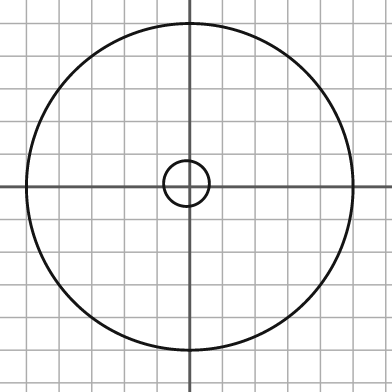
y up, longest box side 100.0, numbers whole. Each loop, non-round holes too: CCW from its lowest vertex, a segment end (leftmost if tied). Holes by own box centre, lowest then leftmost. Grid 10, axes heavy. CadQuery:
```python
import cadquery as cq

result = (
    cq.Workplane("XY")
    .moveTo(0.0, 0.0)
    .circle(50.0)
    .moveTo(-1.0, 1.0)
    .circle(7.0)
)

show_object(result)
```